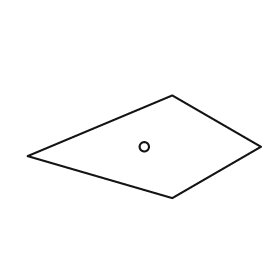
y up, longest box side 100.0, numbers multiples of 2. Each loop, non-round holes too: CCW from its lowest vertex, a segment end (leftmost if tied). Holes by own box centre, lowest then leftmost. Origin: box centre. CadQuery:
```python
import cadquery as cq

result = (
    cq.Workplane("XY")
    .moveTo(12.0, -22.0)
    .lineTo(50.0, 0.0)
    .lineTo(12.0, 22.0)
    .lineTo(-50.0, -4.0)
    .close()
    .moveTo(0.0, 0.0)
    .circle(2.0)
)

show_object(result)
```